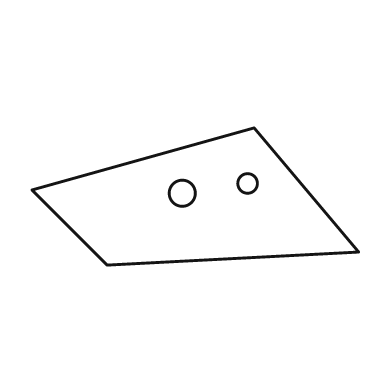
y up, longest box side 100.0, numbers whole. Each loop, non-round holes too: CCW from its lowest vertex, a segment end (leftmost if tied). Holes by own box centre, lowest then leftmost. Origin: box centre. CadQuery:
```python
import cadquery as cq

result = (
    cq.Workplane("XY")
    .moveTo(-27.0, -21.0)
    .lineTo(50.0, -17.0)
    .lineTo(18.0, 21.0)
    .lineTo(-50.0, 2.0)
    .close()
    .moveTo(-4.0, 1.0)
    .circle(4.0)
    .moveTo(16.0, 4.0)
    .circle(3.0)
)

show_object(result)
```